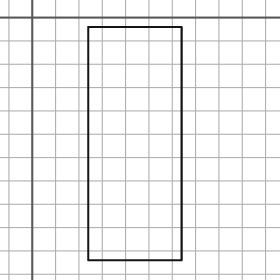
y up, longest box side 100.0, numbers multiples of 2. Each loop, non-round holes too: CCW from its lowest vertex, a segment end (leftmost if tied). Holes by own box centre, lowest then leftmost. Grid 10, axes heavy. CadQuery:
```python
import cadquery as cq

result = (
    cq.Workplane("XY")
    .moveTo(24.0, -104.0)
    .lineTo(64.0, -104.0)
    .lineTo(64.0, -4.0)
    .lineTo(24.0, -4.0)
    .close()
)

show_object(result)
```